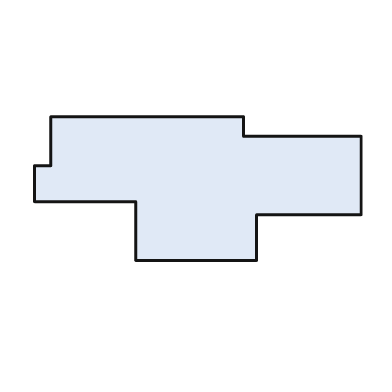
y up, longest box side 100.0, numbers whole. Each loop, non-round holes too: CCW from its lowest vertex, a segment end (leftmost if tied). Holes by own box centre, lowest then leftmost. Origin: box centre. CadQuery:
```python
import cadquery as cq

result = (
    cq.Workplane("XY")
    .moveTo(-19.0, -22.0)
    .lineTo(18.0, -22.0)
    .lineTo(18.0, -8.0)
    .lineTo(50.0, -8.0)
    .lineTo(50.0, 16.0)
    .lineTo(14.0, 16.0)
    .lineTo(14.0, 22.0)
    .lineTo(-45.0, 22.0)
    .lineTo(-45.0, 7.0)
    .lineTo(-50.0, 7.0)
    .lineTo(-50.0, -4.0)
    .lineTo(-19.0, -4.0)
    .close()
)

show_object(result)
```